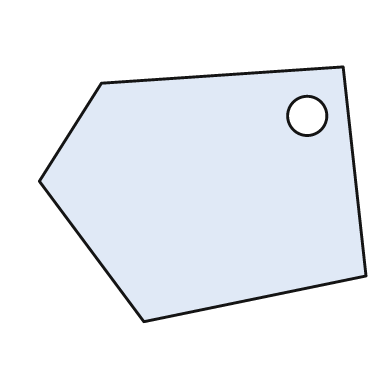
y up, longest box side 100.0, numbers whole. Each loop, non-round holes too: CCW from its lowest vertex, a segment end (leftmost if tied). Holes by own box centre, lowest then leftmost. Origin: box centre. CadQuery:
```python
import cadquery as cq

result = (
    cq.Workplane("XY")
    .moveTo(-18.0, -39.0)
    .lineTo(50.0, -25.0)
    .lineTo(43.0, 39.0)
    .lineTo(-31.0, 34.0)
    .lineTo(-50.0, 4.0)
    .close()
    .moveTo(32.0, 24.0)
    .circle(6.0)
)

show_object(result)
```